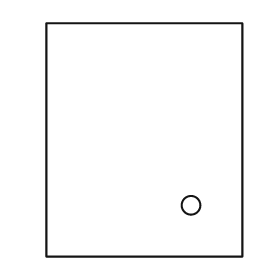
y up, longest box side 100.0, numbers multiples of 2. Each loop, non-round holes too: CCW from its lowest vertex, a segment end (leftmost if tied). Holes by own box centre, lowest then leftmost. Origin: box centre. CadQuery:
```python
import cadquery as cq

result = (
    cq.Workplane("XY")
    .moveTo(-42.0, -50.0)
    .lineTo(42.0, -50.0)
    .lineTo(42.0, 50.0)
    .lineTo(-42.0, 50.0)
    .close()
    .moveTo(20.0, -28.0)
    .circle(4.0)
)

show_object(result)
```